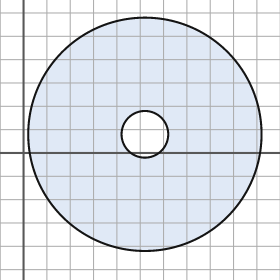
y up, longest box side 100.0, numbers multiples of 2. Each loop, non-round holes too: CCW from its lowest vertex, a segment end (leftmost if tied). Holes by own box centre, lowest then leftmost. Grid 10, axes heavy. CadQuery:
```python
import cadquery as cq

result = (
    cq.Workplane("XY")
    .moveTo(52.0, 8.0)
    .circle(50.0)
    .moveTo(52.0, 8.0)
    .circle(10.0)
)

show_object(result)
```